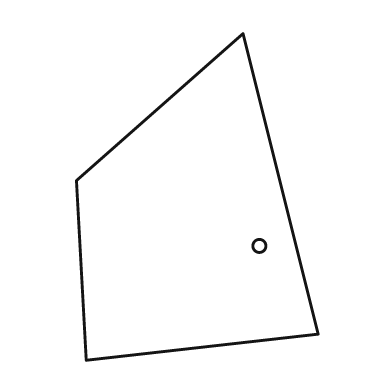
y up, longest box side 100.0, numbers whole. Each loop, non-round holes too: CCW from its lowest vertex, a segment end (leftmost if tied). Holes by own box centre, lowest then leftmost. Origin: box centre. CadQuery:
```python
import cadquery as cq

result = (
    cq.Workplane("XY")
    .moveTo(-34.0, -50.0)
    .lineTo(37.0, -42.0)
    .lineTo(14.0, 50.0)
    .lineTo(-37.0, 5.0)
    .close()
    .moveTo(19.0, -15.0)
    .circle(2.0)
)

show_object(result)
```